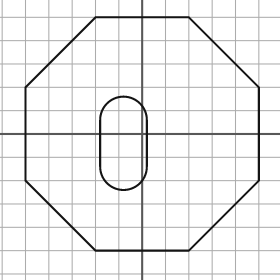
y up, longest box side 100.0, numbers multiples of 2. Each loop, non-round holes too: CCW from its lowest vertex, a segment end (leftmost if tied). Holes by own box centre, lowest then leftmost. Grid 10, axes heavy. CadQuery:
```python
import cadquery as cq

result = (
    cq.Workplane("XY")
    .moveTo(-20.0, -50.0)
    .lineTo(20.0, -50.0)
    .lineTo(50.0, -20.0)
    .lineTo(50.0, 20.0)
    .lineTo(20.0, 50.0)
    .lineTo(-20.0, 50.0)
    .lineTo(-50.0, 20.0)
    .lineTo(-50.0, -20.0)
    .close()
    .moveTo(-18.0, -14.0)
    .threePointArc((-8.0, -24.0), (2.0, -14.0))
    .lineTo(2.0, 6.0)
    .threePointArc((-8.0, 16.0), (-18.0, 6.0))
    .close()
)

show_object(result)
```